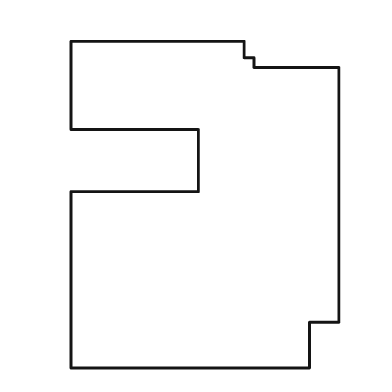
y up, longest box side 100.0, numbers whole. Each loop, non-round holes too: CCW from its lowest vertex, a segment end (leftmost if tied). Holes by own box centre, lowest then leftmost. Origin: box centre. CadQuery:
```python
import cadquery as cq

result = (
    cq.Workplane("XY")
    .moveTo(-41.0, -50.0)
    .lineTo(32.0, -50.0)
    .lineTo(32.0, -36.0)
    .lineTo(41.0, -36.0)
    .lineTo(41.0, 42.0)
    .lineTo(15.0, 42.0)
    .lineTo(15.0, 45.0)
    .lineTo(12.0, 45.0)
    .lineTo(12.0, 50.0)
    .lineTo(-41.0, 50.0)
    .lineTo(-41.0, 23.0)
    .lineTo(-2.0, 23.0)
    .lineTo(-2.0, 4.0)
    .lineTo(-41.0, 4.0)
    .close()
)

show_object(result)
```